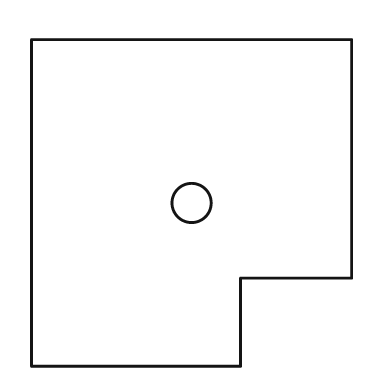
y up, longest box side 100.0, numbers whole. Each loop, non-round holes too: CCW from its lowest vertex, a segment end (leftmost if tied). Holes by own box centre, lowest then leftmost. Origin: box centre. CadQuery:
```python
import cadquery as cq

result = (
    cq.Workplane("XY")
    .moveTo(-49.0, -50.0)
    .lineTo(15.0, -50.0)
    .lineTo(15.0, -23.0)
    .lineTo(49.0, -23.0)
    .lineTo(49.0, 50.0)
    .lineTo(-49.0, 50.0)
    .close()
    .moveTo(0.0, 0.0)
    .circle(6.0)
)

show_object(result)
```